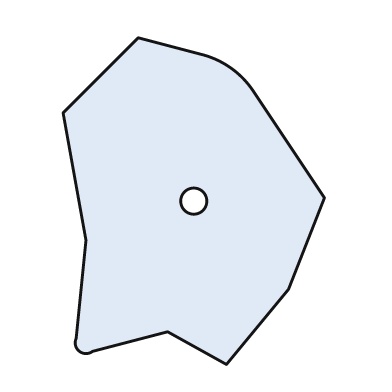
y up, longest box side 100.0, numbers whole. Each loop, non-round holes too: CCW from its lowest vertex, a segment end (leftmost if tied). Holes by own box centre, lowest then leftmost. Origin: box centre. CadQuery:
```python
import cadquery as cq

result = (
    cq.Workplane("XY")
    .moveTo(10.0, -50.0)
    .lineTo(29.0, -27.0)
    .lineTo(40.0, 1.0)
    .lineTo(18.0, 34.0)
    .threePointArc((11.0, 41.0), (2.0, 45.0))
    .lineTo(-17.0, 50.0)
    .lineTo(-40.0, 27.0)
    .lineTo(-33.0, -12.0)
    .lineTo(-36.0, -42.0)
    .threePointArc((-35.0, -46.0), (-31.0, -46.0))
    .lineTo(-8.0, -40.0)
    .close()
    .moveTo(0.0, 0.0)
    .circle(4.0)
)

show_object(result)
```